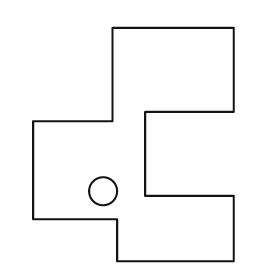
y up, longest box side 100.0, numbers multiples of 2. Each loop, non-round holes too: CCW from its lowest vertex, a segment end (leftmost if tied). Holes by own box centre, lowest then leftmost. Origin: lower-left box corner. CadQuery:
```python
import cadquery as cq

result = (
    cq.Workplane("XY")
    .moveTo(36.0, 0.0)
    .lineTo(86.0, 0.0)
    .lineTo(86.0, 28.0)
    .lineTo(48.0, 28.0)
    .lineTo(48.0, 64.0)
    .lineTo(86.0, 64.0)
    .lineTo(86.0, 100.0)
    .lineTo(34.0, 100.0)
    .lineTo(34.0, 60.0)
    .lineTo(0.0, 60.0)
    .lineTo(0.0, 18.0)
    .lineTo(36.0, 18.0)
    .close()
    .moveTo(30.0, 30.0)
    .circle(6.0)
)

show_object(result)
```